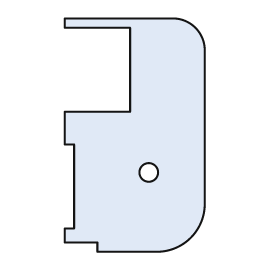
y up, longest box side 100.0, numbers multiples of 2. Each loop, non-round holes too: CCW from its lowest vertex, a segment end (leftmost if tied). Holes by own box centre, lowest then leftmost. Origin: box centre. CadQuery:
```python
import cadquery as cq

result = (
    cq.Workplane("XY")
    .moveTo(-16.0, -50.0)
    .lineTo(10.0, -50.0)
    .threePointArc((24.0, -44.0), (30.0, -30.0))
    .lineTo(30.0, 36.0)
    .threePointArc((26.0, 46.0), (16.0, 50.0))
    .lineTo(-30.0, 50.0)
    .lineTo(-30.0, 46.0)
    .lineTo(-2.0, 46.0)
    .lineTo(-2.0, 10.0)
    .lineTo(-30.0, 10.0)
    .lineTo(-30.0, -4.0)
    .lineTo(-26.0, -4.0)
    .lineTo(-26.0, -40.0)
    .lineTo(-30.0, -40.0)
    .lineTo(-30.0, -46.0)
    .lineTo(-16.0, -46.0)
    .close()
    .moveTo(6.0, -16.0)
    .circle(4.0)
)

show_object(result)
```